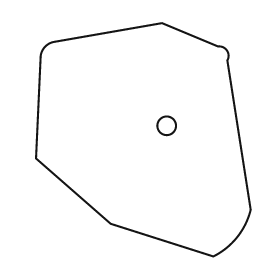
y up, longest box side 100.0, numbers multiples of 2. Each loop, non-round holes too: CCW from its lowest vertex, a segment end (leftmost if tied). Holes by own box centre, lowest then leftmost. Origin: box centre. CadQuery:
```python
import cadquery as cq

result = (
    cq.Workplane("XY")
    .moveTo(30.0, -50.0)
    .threePointArc((40.0, -42.0), (46.0, -30.0))
    .lineTo(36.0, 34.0)
    .threePointArc((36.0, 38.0), (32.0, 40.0))
    .lineTo(8.0, 50.0)
    .lineTo(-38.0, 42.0)
    .threePointArc((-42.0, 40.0), (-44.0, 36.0))
    .lineTo(-46.0, -8.0)
    .lineTo(-14.0, -36.0)
    .close()
    .moveTo(10.0, 6.0)
    .circle(4.0)
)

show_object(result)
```